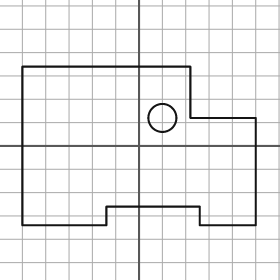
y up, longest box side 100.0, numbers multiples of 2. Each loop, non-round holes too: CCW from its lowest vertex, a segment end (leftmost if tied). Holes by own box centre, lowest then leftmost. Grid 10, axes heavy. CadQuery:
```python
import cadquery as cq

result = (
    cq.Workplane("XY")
    .moveTo(-50.0, -34.0)
    .lineTo(-14.0, -34.0)
    .lineTo(-14.0, -26.0)
    .lineTo(26.0, -26.0)
    .lineTo(26.0, -34.0)
    .lineTo(50.0, -34.0)
    .lineTo(50.0, 12.0)
    .lineTo(22.0, 12.0)
    .lineTo(22.0, 34.0)
    .lineTo(-50.0, 34.0)
    .close()
    .moveTo(10.0, 12.0)
    .circle(6.0)
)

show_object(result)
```